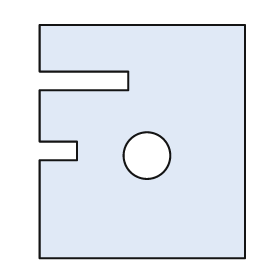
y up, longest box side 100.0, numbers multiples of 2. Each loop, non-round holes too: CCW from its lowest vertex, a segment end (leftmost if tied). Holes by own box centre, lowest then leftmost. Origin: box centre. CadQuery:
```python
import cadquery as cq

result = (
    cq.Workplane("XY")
    .moveTo(-44.0, -50.0)
    .lineTo(44.0, -50.0)
    .lineTo(44.0, 50.0)
    .lineTo(-44.0, 50.0)
    .lineTo(-44.0, 30.0)
    .lineTo(-6.0, 30.0)
    .lineTo(-6.0, 22.0)
    .lineTo(-44.0, 22.0)
    .lineTo(-44.0, 0.0)
    .lineTo(-28.0, 0.0)
    .lineTo(-28.0, -8.0)
    .lineTo(-44.0, -8.0)
    .close()
    .moveTo(2.0, -6.0)
    .circle(10.0)
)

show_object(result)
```